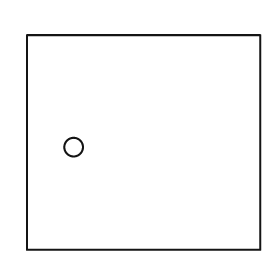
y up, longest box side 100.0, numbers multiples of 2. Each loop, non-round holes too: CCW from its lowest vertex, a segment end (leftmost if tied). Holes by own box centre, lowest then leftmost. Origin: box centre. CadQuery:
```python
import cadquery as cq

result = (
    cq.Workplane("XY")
    .moveTo(-50.0, -46.0)
    .lineTo(50.0, -46.0)
    .lineTo(50.0, 46.0)
    .lineTo(-50.0, 46.0)
    .close()
    .moveTo(-30.0, -2.0)
    .circle(4.0)
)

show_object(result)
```